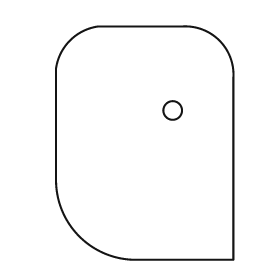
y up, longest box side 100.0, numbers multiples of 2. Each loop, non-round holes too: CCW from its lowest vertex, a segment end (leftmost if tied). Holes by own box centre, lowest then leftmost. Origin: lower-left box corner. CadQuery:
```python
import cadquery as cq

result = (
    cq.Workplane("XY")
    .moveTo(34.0, 0.0)
    .lineTo(76.0, 0.0)
    .lineTo(76.0, 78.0)
    .threePointArc((70.0, 94.0), (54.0, 100.0))
    .lineTo(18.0, 100.0)
    .threePointArc((6.0, 94.0), (0.0, 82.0))
    .lineTo(0.0, 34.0)
    .threePointArc((10.0, 10.0), (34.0, 0.0))
    .close()
    .moveTo(50.0, 64.0)
    .circle(4.0)
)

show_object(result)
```